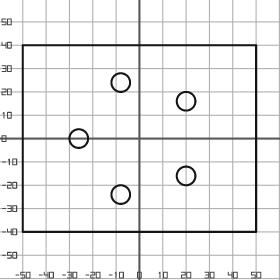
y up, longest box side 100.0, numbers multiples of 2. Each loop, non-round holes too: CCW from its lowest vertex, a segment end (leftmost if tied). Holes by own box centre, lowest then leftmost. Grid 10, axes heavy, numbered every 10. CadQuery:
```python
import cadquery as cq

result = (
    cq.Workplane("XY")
    .moveTo(-50.0, -40.0)
    .lineTo(50.0, -40.0)
    .lineTo(50.0, 40.0)
    .lineTo(-50.0, 40.0)
    .close()
    .moveTo(-8.0, -24.0)
    .circle(4.0)
    .moveTo(20.0, -16.0)
    .circle(4.0)
    .moveTo(-26.0, 0.0)
    .circle(4.0)
    .moveTo(20.0, 16.0)
    .circle(4.0)
    .moveTo(-8.0, 24.0)
    .circle(4.0)
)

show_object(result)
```